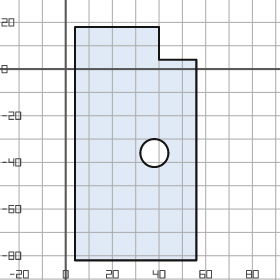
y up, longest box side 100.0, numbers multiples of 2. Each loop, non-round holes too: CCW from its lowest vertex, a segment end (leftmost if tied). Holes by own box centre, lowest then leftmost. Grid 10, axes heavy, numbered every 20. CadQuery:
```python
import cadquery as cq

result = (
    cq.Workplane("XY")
    .moveTo(4.0, -82.0)
    .lineTo(56.0, -82.0)
    .lineTo(56.0, 4.0)
    .lineTo(40.0, 4.0)
    .lineTo(40.0, 18.0)
    .lineTo(4.0, 18.0)
    .close()
    .moveTo(38.0, -36.0)
    .circle(6.0)
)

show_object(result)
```